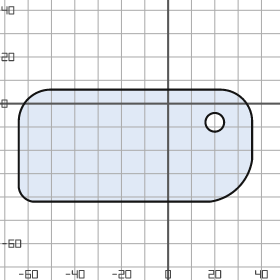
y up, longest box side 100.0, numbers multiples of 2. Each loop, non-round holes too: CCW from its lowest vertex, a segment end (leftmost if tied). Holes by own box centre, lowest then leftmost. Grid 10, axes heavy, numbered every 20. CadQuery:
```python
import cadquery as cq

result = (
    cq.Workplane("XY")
    .moveTo(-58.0, -42.0)
    .lineTo(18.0, -42.0)
    .threePointArc((30.0, -36.0), (36.0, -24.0))
    .lineTo(36.0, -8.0)
    .threePointArc((32.0, 2.0), (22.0, 6.0))
    .lineTo(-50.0, 6.0)
    .threePointArc((-60.0, 2.0), (-64.0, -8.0))
    .lineTo(-64.0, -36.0)
    .threePointArc((-62.0, -40.0), (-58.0, -42.0))
    .close()
    .moveTo(20.0, -8.0)
    .circle(4.0)
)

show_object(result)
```